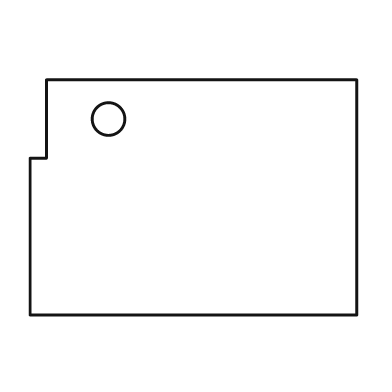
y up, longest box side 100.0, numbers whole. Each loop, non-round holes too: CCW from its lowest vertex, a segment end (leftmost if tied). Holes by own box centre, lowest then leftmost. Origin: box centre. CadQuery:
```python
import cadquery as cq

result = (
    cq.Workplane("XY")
    .moveTo(-50.0, -36.0)
    .lineTo(50.0, -36.0)
    .lineTo(50.0, 36.0)
    .lineTo(-45.0, 36.0)
    .lineTo(-45.0, 12.0)
    .lineTo(-50.0, 12.0)
    .close()
    .moveTo(-26.0, 24.0)
    .circle(5.0)
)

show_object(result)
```